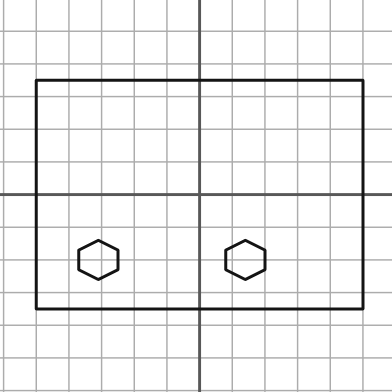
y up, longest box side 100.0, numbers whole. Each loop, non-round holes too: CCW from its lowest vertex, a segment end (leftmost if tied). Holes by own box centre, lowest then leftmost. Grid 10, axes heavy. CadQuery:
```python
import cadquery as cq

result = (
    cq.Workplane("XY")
    .moveTo(-50.0, -35.0)
    .lineTo(50.0, -35.0)
    .lineTo(50.0, 35.0)
    .lineTo(-50.0, 35.0)
    .close()
    .moveTo(-31.0, -26.0)
    .lineTo(-25.0, -23.0)
    .lineTo(-25.0, -17.0)
    .lineTo(-31.0, -14.0)
    .lineTo(-37.0, -17.0)
    .lineTo(-37.0, -23.0)
    .close()
    .moveTo(14.0, -26.0)
    .lineTo(20.0, -23.0)
    .lineTo(20.0, -17.0)
    .lineTo(14.0, -14.0)
    .lineTo(8.0, -17.0)
    .lineTo(8.0, -23.0)
    .close()
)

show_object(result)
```